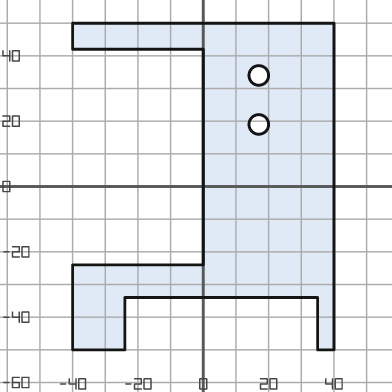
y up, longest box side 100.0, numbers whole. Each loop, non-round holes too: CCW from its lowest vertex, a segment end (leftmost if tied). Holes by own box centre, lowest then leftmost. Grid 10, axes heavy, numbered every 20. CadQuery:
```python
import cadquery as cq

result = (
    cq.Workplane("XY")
    .moveTo(-40.0, -50.0)
    .lineTo(-24.0, -50.0)
    .lineTo(-24.0, -34.0)
    .lineTo(35.0, -34.0)
    .lineTo(35.0, -50.0)
    .lineTo(40.0, -50.0)
    .lineTo(40.0, 50.0)
    .lineTo(-40.0, 50.0)
    .lineTo(-40.0, 42.0)
    .lineTo(0.0, 42.0)
    .lineTo(0.0, -24.0)
    .lineTo(-40.0, -24.0)
    .close()
    .moveTo(17.0, 19.0)
    .circle(3.0)
    .moveTo(17.0, 34.0)
    .circle(3.0)
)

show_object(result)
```